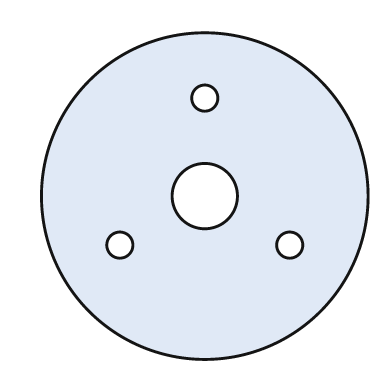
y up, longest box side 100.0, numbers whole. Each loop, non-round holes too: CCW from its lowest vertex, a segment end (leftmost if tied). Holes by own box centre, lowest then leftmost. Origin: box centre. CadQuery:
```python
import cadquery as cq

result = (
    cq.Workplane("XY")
    .moveTo(0.0, 0.0)
    .circle(50.0)
    .moveTo(-26.0, -15.0)
    .circle(4.0)
    .moveTo(26.0, -15.0)
    .circle(4.0)
    .moveTo(0.0, 0.0)
    .circle(10.0)
    .moveTo(0.0, 30.0)
    .circle(4.0)
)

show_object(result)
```